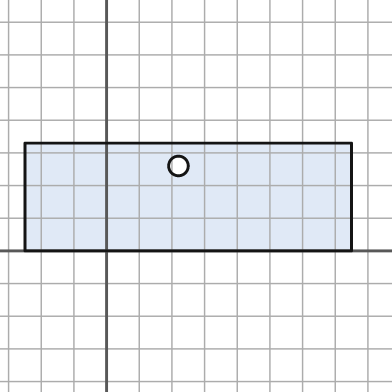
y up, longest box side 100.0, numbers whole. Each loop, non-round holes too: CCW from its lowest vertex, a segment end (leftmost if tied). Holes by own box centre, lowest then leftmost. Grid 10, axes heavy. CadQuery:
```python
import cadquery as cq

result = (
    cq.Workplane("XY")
    .moveTo(-25.0, 0.0)
    .lineTo(75.0, 0.0)
    .lineTo(75.0, 33.0)
    .lineTo(-25.0, 33.0)
    .close()
    .moveTo(22.0, 26.0)
    .circle(3.0)
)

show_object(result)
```